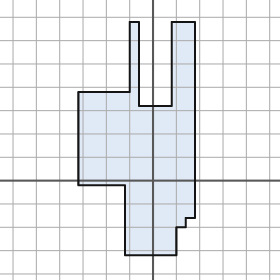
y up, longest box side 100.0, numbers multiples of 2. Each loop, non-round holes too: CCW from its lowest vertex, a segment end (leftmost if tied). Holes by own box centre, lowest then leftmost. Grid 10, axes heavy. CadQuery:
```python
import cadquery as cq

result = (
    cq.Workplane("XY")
    .moveTo(-12.0, -32.0)
    .lineTo(10.0, -32.0)
    .lineTo(10.0, -20.0)
    .lineTo(14.0, -20.0)
    .lineTo(14.0, -16.0)
    .lineTo(18.0, -16.0)
    .lineTo(18.0, 68.0)
    .lineTo(8.0, 68.0)
    .lineTo(8.0, 32.0)
    .lineTo(-6.0, 32.0)
    .lineTo(-6.0, 68.0)
    .lineTo(-10.0, 68.0)
    .lineTo(-10.0, 38.0)
    .lineTo(-32.0, 38.0)
    .lineTo(-32.0, -2.0)
    .lineTo(-12.0, -2.0)
    .close()
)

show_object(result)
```